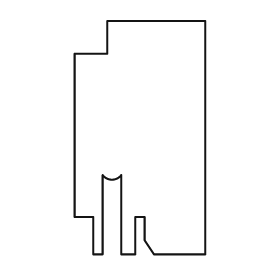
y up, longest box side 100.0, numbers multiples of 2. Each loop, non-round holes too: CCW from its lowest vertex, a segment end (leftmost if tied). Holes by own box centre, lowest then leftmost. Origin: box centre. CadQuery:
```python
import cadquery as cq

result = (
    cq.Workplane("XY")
    .moveTo(-20.0, -50.0)
    .lineTo(-16.0, -50.0)
    .lineTo(-16.0, -16.0)
    .threePointArc((-12.0, -18.0), (-8.0, -16.0))
    .lineTo(-8.0, -50.0)
    .lineTo(-2.0, -50.0)
    .lineTo(-2.0, -34.0)
    .lineTo(2.0, -34.0)
    .lineTo(2.0, -44.0)
    .lineTo(6.0, -50.0)
    .lineTo(28.0, -50.0)
    .lineTo(28.0, 50.0)
    .lineTo(-14.0, 50.0)
    .lineTo(-14.0, 36.0)
    .lineTo(-28.0, 36.0)
    .lineTo(-28.0, -34.0)
    .lineTo(-20.0, -34.0)
    .close()
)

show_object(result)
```